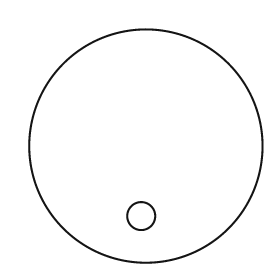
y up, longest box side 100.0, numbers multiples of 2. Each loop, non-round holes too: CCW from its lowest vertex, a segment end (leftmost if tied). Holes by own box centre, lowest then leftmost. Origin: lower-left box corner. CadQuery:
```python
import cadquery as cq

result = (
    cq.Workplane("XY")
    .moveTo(50.0, 50.0)
    .circle(50.0)
    .moveTo(48.0, 20.0)
    .circle(6.0)
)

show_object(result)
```